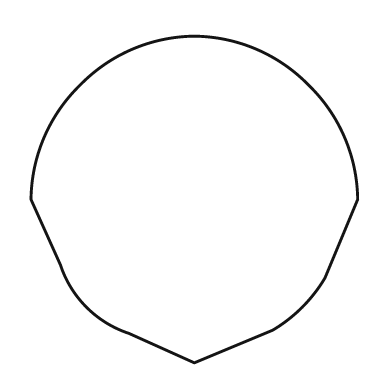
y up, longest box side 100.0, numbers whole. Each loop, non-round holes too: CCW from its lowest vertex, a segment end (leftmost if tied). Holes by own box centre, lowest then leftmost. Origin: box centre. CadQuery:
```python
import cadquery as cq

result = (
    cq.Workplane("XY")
    .moveTo(0.0, -50.0)
    .lineTo(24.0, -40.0)
    .threePointArc((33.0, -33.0), (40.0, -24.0))
    .lineTo(50.0, 0.0)
    .threePointArc((46.0, 19.0), (35.0, 35.0))
    .threePointArc((19.0, 46.0), (0.0, 50.0))
    .threePointArc((-19.0, 46.0), (-35.0, 35.0))
    .threePointArc((-46.0, 19.0), (-50.0, 0.0))
    .lineTo(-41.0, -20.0)
    .threePointArc((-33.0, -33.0), (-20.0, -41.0))
    .close()
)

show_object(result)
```